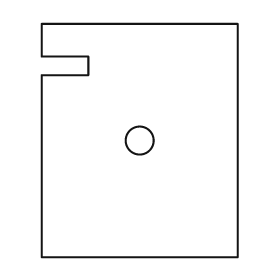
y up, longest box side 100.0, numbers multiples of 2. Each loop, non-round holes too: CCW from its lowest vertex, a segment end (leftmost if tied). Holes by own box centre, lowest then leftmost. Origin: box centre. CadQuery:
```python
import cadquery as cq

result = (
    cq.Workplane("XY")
    .moveTo(-42.0, -50.0)
    .lineTo(42.0, -50.0)
    .lineTo(42.0, 50.0)
    .lineTo(-42.0, 50.0)
    .lineTo(-42.0, 36.0)
    .lineTo(-22.0, 36.0)
    .lineTo(-22.0, 28.0)
    .lineTo(-42.0, 28.0)
    .close()
    .moveTo(0.0, 0.0)
    .circle(6.0)
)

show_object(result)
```